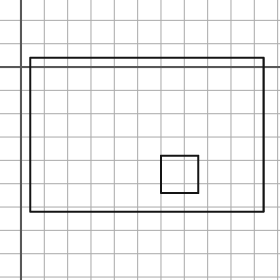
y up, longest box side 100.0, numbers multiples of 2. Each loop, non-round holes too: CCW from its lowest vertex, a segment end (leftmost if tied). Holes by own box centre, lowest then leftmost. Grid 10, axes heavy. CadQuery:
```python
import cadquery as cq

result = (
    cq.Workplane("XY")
    .moveTo(4.0, -62.0)
    .lineTo(104.0, -62.0)
    .lineTo(104.0, 4.0)
    .lineTo(4.0, 4.0)
    .close()
    .moveTo(60.0, -54.0)
    .lineTo(76.0, -54.0)
    .lineTo(76.0, -38.0)
    .lineTo(60.0, -38.0)
    .close()
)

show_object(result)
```